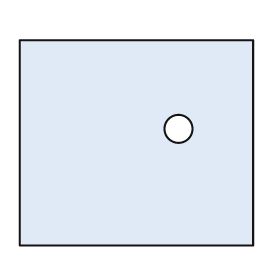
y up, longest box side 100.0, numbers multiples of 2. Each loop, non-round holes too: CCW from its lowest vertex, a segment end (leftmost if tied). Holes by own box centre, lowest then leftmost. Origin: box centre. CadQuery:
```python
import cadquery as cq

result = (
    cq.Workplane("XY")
    .moveTo(-50.0, -44.0)
    .lineTo(50.0, -44.0)
    .lineTo(50.0, 44.0)
    .lineTo(-50.0, 44.0)
    .close()
    .moveTo(18.0, 6.0)
    .circle(6.0)
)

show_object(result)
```